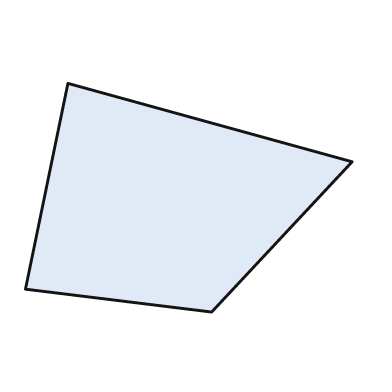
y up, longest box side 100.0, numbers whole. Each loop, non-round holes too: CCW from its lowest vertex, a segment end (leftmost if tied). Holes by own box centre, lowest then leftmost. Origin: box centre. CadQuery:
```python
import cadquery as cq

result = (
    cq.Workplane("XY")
    .moveTo(7.0, -35.0)
    .lineTo(50.0, 11.0)
    .lineTo(-37.0, 35.0)
    .lineTo(-50.0, -28.0)
    .close()
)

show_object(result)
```